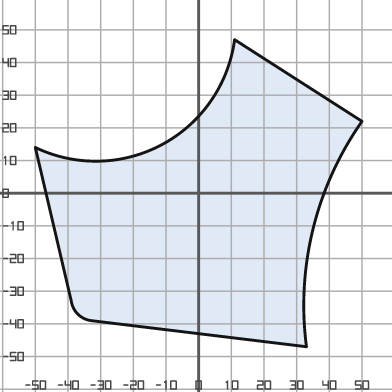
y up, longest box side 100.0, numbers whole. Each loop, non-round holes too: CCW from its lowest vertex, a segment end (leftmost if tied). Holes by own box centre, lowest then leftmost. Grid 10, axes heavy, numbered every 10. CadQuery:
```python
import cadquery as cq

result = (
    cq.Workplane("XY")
    .moveTo(33.0, -47.0)
    .threePointArc((35.0, -11.0), (50.0, 22.0))
    .lineTo(11.0, 47.0)
    .threePointArc((-11.0, 15.0), (-50.0, 14.0))
    .lineTo(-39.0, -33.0)
    .threePointArc((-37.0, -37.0), (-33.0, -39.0))
    .close()
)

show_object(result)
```